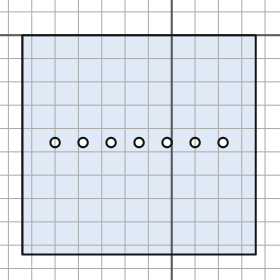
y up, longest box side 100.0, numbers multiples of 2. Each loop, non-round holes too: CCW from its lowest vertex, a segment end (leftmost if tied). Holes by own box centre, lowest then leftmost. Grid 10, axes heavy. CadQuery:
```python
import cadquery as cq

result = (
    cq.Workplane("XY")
    .moveTo(-64.0, -94.0)
    .lineTo(36.0, -94.0)
    .lineTo(36.0, 0.0)
    .lineTo(-64.0, 0.0)
    .close()
    .moveTo(-50.0, -46.0)
    .circle(2.0)
    .moveTo(-38.0, -46.0)
    .circle(2.0)
    .moveTo(-26.0, -46.0)
    .circle(2.0)
    .moveTo(-14.0, -46.0)
    .circle(2.0)
    .moveTo(-2.0, -46.0)
    .circle(2.0)
    .moveTo(10.0, -46.0)
    .circle(2.0)
    .moveTo(22.0, -46.0)
    .circle(2.0)
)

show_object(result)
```